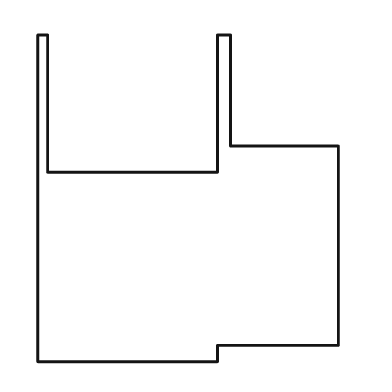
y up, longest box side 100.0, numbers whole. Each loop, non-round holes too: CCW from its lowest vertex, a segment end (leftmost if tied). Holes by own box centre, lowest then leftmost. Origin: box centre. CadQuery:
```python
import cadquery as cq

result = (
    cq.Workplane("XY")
    .moveTo(-46.0, -50.0)
    .lineTo(9.0, -50.0)
    .lineTo(9.0, -45.0)
    .lineTo(46.0, -45.0)
    .lineTo(46.0, 16.0)
    .lineTo(13.0, 16.0)
    .lineTo(13.0, 50.0)
    .lineTo(9.0, 50.0)
    .lineTo(9.0, 8.0)
    .lineTo(-43.0, 8.0)
    .lineTo(-43.0, 50.0)
    .lineTo(-46.0, 50.0)
    .close()
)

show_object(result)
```